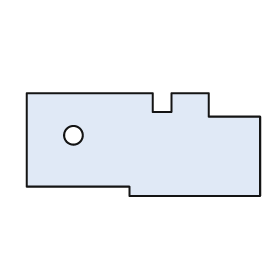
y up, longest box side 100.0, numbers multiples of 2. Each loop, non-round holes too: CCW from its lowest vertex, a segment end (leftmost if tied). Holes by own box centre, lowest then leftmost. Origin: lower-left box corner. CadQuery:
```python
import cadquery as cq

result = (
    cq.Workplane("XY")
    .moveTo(44.0, 0.0)
    .lineTo(100.0, 0.0)
    .lineTo(100.0, 34.0)
    .lineTo(78.0, 34.0)
    .lineTo(78.0, 44.0)
    .lineTo(62.0, 44.0)
    .lineTo(62.0, 36.0)
    .lineTo(54.0, 36.0)
    .lineTo(54.0, 44.0)
    .lineTo(0.0, 44.0)
    .lineTo(0.0, 4.0)
    .lineTo(44.0, 4.0)
    .close()
    .moveTo(20.0, 26.0)
    .circle(4.0)
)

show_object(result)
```